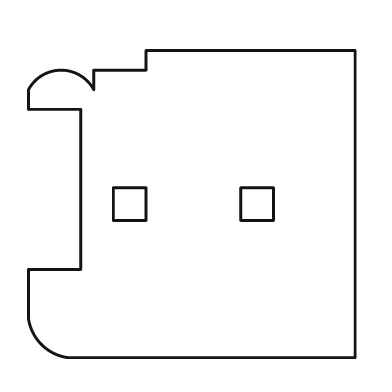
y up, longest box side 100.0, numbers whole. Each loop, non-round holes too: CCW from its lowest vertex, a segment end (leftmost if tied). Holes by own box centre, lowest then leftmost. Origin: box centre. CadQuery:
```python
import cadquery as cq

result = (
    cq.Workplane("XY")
    .moveTo(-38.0, -47.0)
    .lineTo(50.0, -47.0)
    .lineTo(50.0, 47.0)
    .lineTo(-14.0, 47.0)
    .lineTo(-14.0, 41.0)
    .lineTo(-30.0, 41.0)
    .lineTo(-30.0, 35.0)
    .threePointArc((-40.0, 41.0), (-50.0, 35.0))
    .lineTo(-50.0, 29.0)
    .lineTo(-34.0, 29.0)
    .lineTo(-34.0, -20.0)
    .lineTo(-50.0, -20.0)
    .lineTo(-50.0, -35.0)
    .threePointArc((-46.0, -43.0), (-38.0, -47.0))
    .close()
    .moveTo(-24.0, -5.0)
    .lineTo(-14.0, -5.0)
    .lineTo(-14.0, 5.0)
    .lineTo(-24.0, 5.0)
    .close()
    .moveTo(15.0, -5.0)
    .lineTo(25.0, -5.0)
    .lineTo(25.0, 5.0)
    .lineTo(15.0, 5.0)
    .close()
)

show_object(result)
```